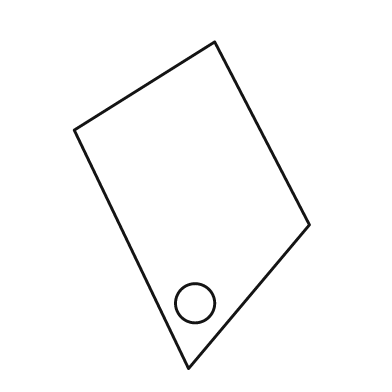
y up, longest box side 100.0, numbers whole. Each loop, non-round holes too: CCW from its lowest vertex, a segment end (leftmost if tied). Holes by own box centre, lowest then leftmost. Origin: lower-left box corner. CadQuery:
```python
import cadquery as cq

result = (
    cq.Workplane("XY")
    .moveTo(35.0, 0.0)
    .lineTo(72.0, 44.0)
    .lineTo(43.0, 100.0)
    .lineTo(0.0, 73.0)
    .close()
    .moveTo(37.0, 20.0)
    .circle(6.0)
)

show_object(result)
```